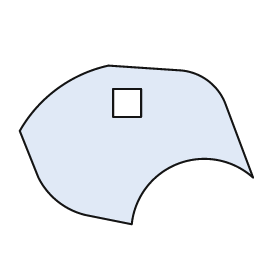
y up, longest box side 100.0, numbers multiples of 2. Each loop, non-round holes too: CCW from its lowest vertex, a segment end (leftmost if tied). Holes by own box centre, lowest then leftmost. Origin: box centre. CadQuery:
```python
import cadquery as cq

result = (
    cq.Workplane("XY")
    .moveTo(-2.0, -34.0)
    .threePointArc((18.0, -8.0), (50.0, -14.0))
    .lineTo(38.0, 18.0)
    .threePointArc((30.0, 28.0), (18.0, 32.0))
    .lineTo(-12.0, 34.0)
    .threePointArc((-34.0, 24.0), (-50.0, 6.0))
    .lineTo(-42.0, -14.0)
    .threePointArc((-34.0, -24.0), (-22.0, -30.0))
    .close()
    .moveTo(-10.0, 12.0)
    .lineTo(2.0, 12.0)
    .lineTo(2.0, 24.0)
    .lineTo(-10.0, 24.0)
    .close()
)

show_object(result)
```